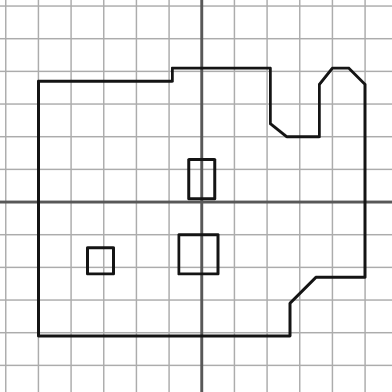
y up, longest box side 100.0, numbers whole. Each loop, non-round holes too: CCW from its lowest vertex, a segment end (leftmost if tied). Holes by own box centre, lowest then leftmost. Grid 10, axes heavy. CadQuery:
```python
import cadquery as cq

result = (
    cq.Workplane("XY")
    .moveTo(-50.0, -41.0)
    .lineTo(27.0, -41.0)
    .lineTo(27.0, -31.0)
    .lineTo(35.0, -23.0)
    .lineTo(50.0, -23.0)
    .lineTo(50.0, 36.0)
    .lineTo(45.0, 41.0)
    .lineTo(40.0, 41.0)
    .lineTo(36.0, 36.0)
    .lineTo(36.0, 20.0)
    .lineTo(26.0, 20.0)
    .lineTo(21.0, 24.0)
    .lineTo(21.0, 41.0)
    .lineTo(-9.0, 41.0)
    .lineTo(-9.0, 37.0)
    .lineTo(-50.0, 37.0)
    .close()
    .moveTo(-35.0, -22.0)
    .lineTo(-27.0, -22.0)
    .lineTo(-27.0, -14.0)
    .lineTo(-35.0, -14.0)
    .close()
    .moveTo(-7.0, -22.0)
    .lineTo(5.0, -22.0)
    .lineTo(5.0, -10.0)
    .lineTo(-7.0, -10.0)
    .close()
    .moveTo(-4.0, 1.0)
    .lineTo(4.0, 1.0)
    .lineTo(4.0, 13.0)
    .lineTo(-4.0, 13.0)
    .close()
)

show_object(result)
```